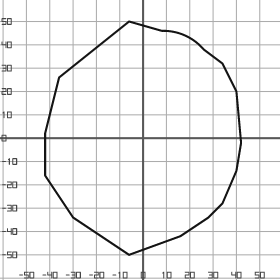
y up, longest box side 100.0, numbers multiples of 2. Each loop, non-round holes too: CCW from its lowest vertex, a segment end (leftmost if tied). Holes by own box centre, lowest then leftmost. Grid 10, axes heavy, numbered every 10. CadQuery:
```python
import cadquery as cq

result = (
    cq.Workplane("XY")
    .moveTo(-6.0, -50.0)
    .lineTo(16.0, -42.0)
    .lineTo(28.0, -34.0)
    .lineTo(34.0, -28.0)
    .lineTo(40.0, -14.0)
    .lineTo(42.0, -2.0)
    .lineTo(40.0, 20.0)
    .lineTo(34.0, 32.0)
    .lineTo(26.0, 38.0)
    .threePointArc((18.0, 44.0), (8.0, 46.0))
    .lineTo(-6.0, 50.0)
    .lineTo(-36.0, 26.0)
    .lineTo(-42.0, 2.0)
    .lineTo(-42.0, -16.0)
    .lineTo(-30.0, -34.0)
    .close()
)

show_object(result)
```